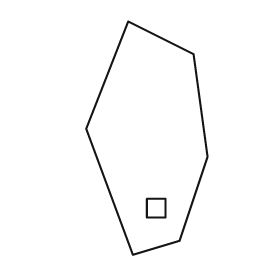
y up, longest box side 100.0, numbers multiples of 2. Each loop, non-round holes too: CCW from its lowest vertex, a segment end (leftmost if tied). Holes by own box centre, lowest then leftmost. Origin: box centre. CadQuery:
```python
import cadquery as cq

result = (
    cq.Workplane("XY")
    .moveTo(-6.0, -50.0)
    .lineTo(14.0, -44.0)
    .lineTo(26.0, -8.0)
    .lineTo(20.0, 36.0)
    .lineTo(-8.0, 50.0)
    .lineTo(-26.0, 4.0)
    .close()
    .moveTo(0.0, -34.0)
    .lineTo(8.0, -34.0)
    .lineTo(8.0, -26.0)
    .lineTo(0.0, -26.0)
    .close()
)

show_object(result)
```